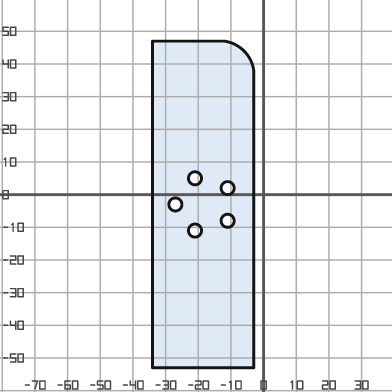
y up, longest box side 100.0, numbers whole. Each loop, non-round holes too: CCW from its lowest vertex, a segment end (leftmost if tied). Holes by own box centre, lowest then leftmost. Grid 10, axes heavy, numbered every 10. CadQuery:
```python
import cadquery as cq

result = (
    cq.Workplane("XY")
    .moveTo(-34.0, -53.0)
    .lineTo(-3.0, -53.0)
    .lineTo(-3.0, 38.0)
    .threePointArc((-6.0, 44.0), (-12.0, 47.0))
    .lineTo(-34.0, 47.0)
    .close()
    .moveTo(-21.0, -11.0)
    .circle(2.0)
    .moveTo(-11.0, -8.0)
    .circle(2.0)
    .moveTo(-27.0, -3.0)
    .circle(2.0)
    .moveTo(-11.0, 2.0)
    .circle(2.0)
    .moveTo(-21.0, 5.0)
    .circle(2.0)
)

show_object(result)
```